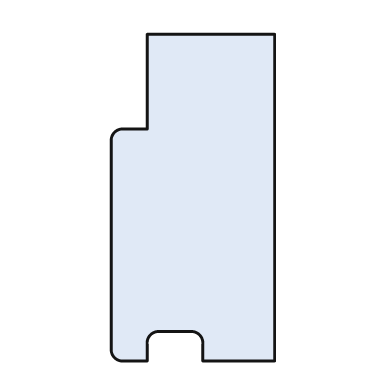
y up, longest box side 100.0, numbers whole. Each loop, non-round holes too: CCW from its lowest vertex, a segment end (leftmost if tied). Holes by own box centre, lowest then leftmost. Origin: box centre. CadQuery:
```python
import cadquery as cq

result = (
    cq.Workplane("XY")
    .moveTo(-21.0, -50.0)
    .lineTo(-14.0, -50.0)
    .lineTo(-14.0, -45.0)
    .threePointArc((-13.0, -42.0), (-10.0, -41.0))
    .lineTo(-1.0, -41.0)
    .threePointArc((2.0, -42.0), (3.0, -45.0))
    .lineTo(3.0, -50.0)
    .lineTo(25.0, -50.0)
    .lineTo(25.0, 50.0)
    .lineTo(-14.0, 50.0)
    .lineTo(-14.0, 21.0)
    .lineTo(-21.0, 21.0)
    .threePointArc((-24.0, 20.0), (-25.0, 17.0))
    .lineTo(-25.0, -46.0)
    .threePointArc((-24.0, -49.0), (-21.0, -50.0))
    .close()
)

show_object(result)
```